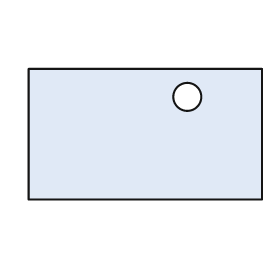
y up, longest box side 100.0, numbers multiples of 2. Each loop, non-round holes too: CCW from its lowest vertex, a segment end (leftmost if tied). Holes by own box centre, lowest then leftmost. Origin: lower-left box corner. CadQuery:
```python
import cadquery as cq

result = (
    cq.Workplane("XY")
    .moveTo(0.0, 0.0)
    .lineTo(100.0, 0.0)
    .lineTo(100.0, 56.0)
    .lineTo(0.0, 56.0)
    .close()
    .moveTo(68.0, 44.0)
    .circle(6.0)
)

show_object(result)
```